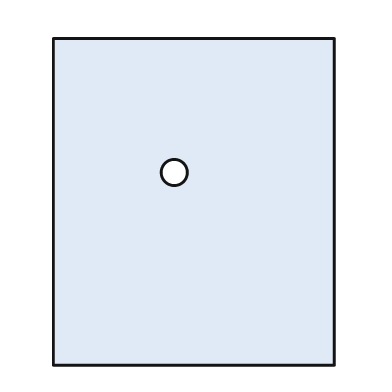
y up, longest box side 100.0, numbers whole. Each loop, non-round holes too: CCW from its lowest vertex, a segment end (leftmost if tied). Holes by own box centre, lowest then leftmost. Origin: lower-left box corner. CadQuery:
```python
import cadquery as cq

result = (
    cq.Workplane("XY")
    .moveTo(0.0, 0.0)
    .lineTo(86.0, 0.0)
    .lineTo(86.0, 100.0)
    .lineTo(0.0, 100.0)
    .close()
    .moveTo(37.0, 59.0)
    .circle(4.0)
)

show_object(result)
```